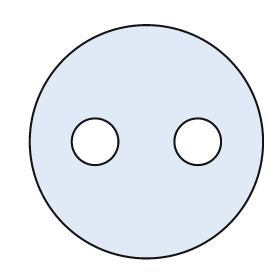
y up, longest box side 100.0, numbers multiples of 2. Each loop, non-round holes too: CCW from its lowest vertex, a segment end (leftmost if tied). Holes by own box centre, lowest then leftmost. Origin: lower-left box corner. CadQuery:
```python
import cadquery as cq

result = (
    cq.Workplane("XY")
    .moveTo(50.0, 50.0)
    .circle(50.0)
    .moveTo(28.0, 50.0)
    .circle(10.0)
    .moveTo(72.0, 50.0)
    .circle(10.0)
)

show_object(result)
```